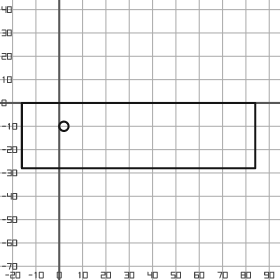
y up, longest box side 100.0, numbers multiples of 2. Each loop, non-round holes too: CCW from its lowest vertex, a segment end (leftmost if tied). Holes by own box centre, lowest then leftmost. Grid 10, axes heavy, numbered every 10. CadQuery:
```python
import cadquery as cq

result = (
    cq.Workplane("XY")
    .moveTo(-16.0, -28.0)
    .lineTo(84.0, -28.0)
    .lineTo(84.0, 0.0)
    .lineTo(-16.0, 0.0)
    .close()
    .moveTo(2.0, -10.0)
    .circle(2.0)
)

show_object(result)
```